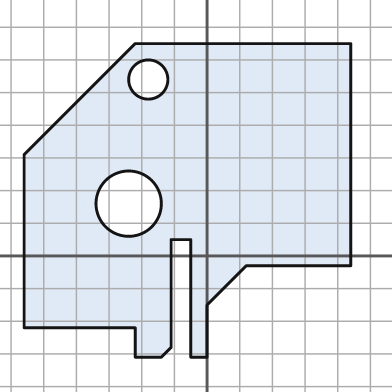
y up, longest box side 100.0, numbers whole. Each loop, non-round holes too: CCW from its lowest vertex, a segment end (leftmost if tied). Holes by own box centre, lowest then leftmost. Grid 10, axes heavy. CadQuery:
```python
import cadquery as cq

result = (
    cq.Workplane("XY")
    .moveTo(-22.0, -31.0)
    .lineTo(-14.0, -31.0)
    .lineTo(-11.0, -28.0)
    .lineTo(-11.0, 5.0)
    .lineTo(-5.0, 5.0)
    .lineTo(-5.0, -31.0)
    .lineTo(0.0, -31.0)
    .lineTo(0.0, -15.0)
    .lineTo(12.0, -3.0)
    .lineTo(44.0, -3.0)
    .lineTo(44.0, 65.0)
    .lineTo(-22.0, 65.0)
    .lineTo(-56.0, 31.0)
    .lineTo(-56.0, -22.0)
    .lineTo(-22.0, -22.0)
    .close()
    .moveTo(-24.0, 16.0)
    .circle(10.0)
    .moveTo(-18.0, 54.0)
    .circle(6.0)
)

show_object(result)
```